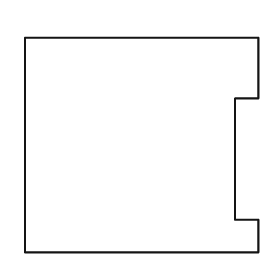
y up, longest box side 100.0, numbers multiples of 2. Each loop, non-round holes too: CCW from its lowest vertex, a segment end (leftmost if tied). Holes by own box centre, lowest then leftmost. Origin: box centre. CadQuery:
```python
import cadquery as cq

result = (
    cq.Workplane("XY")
    .moveTo(-50.0, -46.0)
    .lineTo(50.0, -46.0)
    .lineTo(50.0, -32.0)
    .lineTo(40.0, -32.0)
    .lineTo(40.0, 20.0)
    .lineTo(50.0, 20.0)
    .lineTo(50.0, 46.0)
    .lineTo(-50.0, 46.0)
    .close()
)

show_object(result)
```